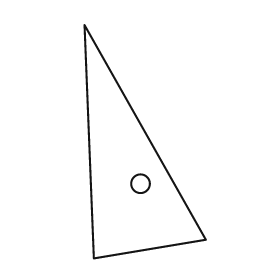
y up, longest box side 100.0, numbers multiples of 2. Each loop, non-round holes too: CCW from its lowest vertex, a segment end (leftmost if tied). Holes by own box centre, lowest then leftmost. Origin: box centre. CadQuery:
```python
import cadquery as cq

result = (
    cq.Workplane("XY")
    .moveTo(-22.0, -50.0)
    .lineTo(26.0, -42.0)
    .lineTo(-26.0, 50.0)
    .close()
    .moveTo(-2.0, -18.0)
    .circle(4.0)
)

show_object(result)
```